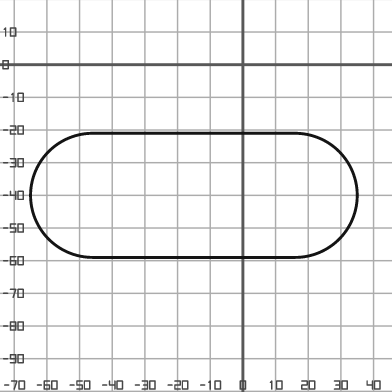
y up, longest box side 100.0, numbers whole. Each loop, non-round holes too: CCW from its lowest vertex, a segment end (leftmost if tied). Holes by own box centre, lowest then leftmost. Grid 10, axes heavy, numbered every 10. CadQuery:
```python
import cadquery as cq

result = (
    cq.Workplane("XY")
    .moveTo(-46.0, -59.0)
    .lineTo(16.0, -59.0)
    .threePointArc((35.0, -40.0), (16.0, -21.0))
    .lineTo(-46.0, -21.0)
    .threePointArc((-65.0, -40.0), (-46.0, -59.0))
    .close()
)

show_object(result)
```